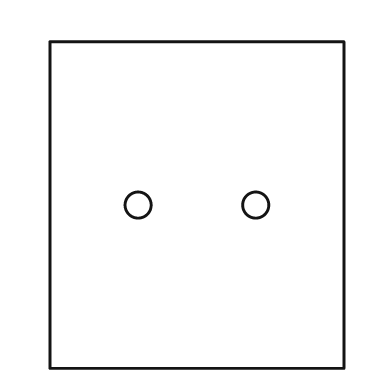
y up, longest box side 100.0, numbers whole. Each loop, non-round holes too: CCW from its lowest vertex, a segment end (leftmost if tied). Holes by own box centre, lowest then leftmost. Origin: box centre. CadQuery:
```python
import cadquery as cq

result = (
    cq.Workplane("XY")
    .moveTo(-45.0, -50.0)
    .lineTo(45.0, -50.0)
    .lineTo(45.0, 50.0)
    .lineTo(-45.0, 50.0)
    .close()
    .moveTo(-18.0, 0.0)
    .circle(4.0)
    .moveTo(18.0, 0.0)
    .circle(4.0)
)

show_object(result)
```